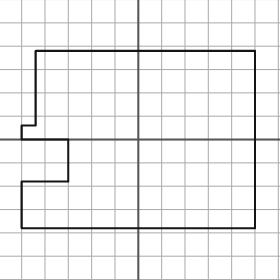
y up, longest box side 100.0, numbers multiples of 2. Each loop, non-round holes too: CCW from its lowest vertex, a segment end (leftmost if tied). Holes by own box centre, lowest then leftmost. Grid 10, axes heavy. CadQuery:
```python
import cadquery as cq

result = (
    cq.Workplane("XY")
    .moveTo(-50.0, -38.0)
    .lineTo(50.0, -38.0)
    .lineTo(50.0, 38.0)
    .lineTo(-44.0, 38.0)
    .lineTo(-44.0, 6.0)
    .lineTo(-50.0, 6.0)
    .lineTo(-50.0, 0.0)
    .lineTo(-30.0, 0.0)
    .lineTo(-30.0, -18.0)
    .lineTo(-50.0, -18.0)
    .close()
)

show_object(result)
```